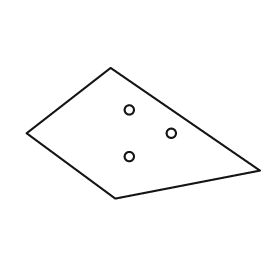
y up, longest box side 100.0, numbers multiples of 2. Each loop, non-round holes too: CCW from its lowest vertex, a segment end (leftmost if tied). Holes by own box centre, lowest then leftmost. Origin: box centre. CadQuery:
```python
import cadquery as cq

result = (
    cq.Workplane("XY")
    .moveTo(-12.0, -28.0)
    .lineTo(50.0, -16.0)
    .lineTo(-14.0, 28.0)
    .lineTo(-50.0, 0.0)
    .close()
    .moveTo(-6.0, -10.0)
    .circle(2.0)
    .moveTo(12.0, 0.0)
    .circle(2.0)
    .moveTo(-6.0, 10.0)
    .circle(2.0)
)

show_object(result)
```